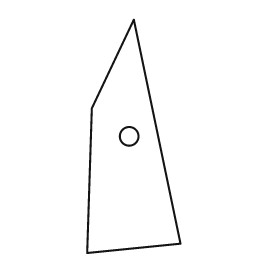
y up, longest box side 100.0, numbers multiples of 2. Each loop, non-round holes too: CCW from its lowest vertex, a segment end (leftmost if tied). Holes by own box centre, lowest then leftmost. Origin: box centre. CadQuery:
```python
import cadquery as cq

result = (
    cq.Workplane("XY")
    .moveTo(-20.0, -50.0)
    .lineTo(20.0, -46.0)
    .lineTo(0.0, 50.0)
    .lineTo(-18.0, 12.0)
    .close()
    .moveTo(-2.0, 0.0)
    .circle(4.0)
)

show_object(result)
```